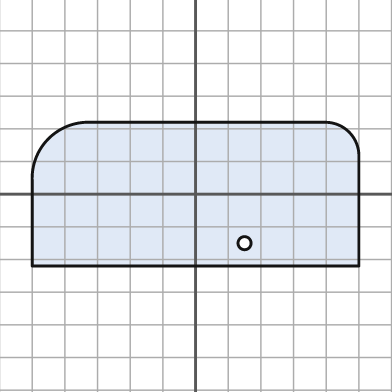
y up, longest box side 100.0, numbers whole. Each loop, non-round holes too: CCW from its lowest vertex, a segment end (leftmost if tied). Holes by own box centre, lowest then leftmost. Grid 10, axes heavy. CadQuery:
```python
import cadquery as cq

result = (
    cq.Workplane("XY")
    .moveTo(-50.0, -22.0)
    .lineTo(50.0, -22.0)
    .lineTo(50.0, 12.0)
    .threePointArc((47.0, 19.0), (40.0, 22.0))
    .lineTo(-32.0, 22.0)
    .threePointArc((-45.0, 17.0), (-50.0, 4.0))
    .close()
    .moveTo(15.0, -15.0)
    .circle(2.0)
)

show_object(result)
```